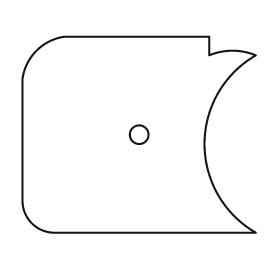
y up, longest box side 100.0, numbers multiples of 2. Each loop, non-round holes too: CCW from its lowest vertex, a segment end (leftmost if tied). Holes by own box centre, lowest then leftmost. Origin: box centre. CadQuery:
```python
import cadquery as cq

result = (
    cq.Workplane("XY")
    .moveTo(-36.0, -42.0)
    .lineTo(50.0, -42.0)
    .threePointArc((28.0, -4.0), (50.0, 34.0))
    .threePointArc((40.0, 36.0), (30.0, 34.0))
    .lineTo(30.0, 42.0)
    .lineTo(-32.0, 42.0)
    .threePointArc((-44.0, 36.0), (-50.0, 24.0))
    .lineTo(-50.0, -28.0)
    .threePointArc((-46.0, -38.0), (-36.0, -42.0))
    .close()
    .moveTo(0.0, 0.0)
    .circle(4.0)
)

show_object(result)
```